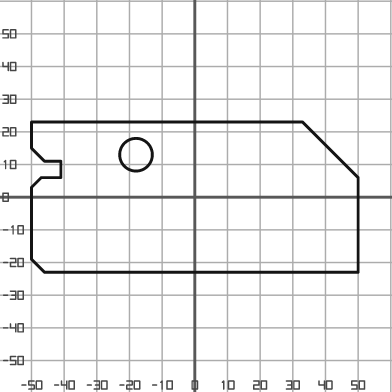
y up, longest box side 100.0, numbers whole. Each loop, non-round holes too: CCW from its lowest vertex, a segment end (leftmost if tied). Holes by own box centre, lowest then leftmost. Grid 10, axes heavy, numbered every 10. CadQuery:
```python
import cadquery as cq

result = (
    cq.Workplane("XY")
    .moveTo(-46.0, -23.0)
    .lineTo(50.0, -23.0)
    .lineTo(50.0, 6.0)
    .lineTo(33.0, 23.0)
    .lineTo(-50.0, 23.0)
    .lineTo(-50.0, 15.0)
    .lineTo(-46.0, 11.0)
    .lineTo(-41.0, 11.0)
    .lineTo(-41.0, 6.0)
    .lineTo(-47.0, 6.0)
    .lineTo(-50.0, 3.0)
    .lineTo(-50.0, -19.0)
    .close()
    .moveTo(-18.0, 13.0)
    .circle(5.0)
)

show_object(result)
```